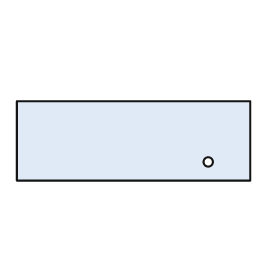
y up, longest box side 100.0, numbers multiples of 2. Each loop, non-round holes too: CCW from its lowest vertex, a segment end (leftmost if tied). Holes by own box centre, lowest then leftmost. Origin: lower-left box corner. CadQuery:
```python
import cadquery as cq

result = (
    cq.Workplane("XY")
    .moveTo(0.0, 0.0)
    .lineTo(100.0, 0.0)
    .lineTo(100.0, 34.0)
    .lineTo(0.0, 34.0)
    .close()
    .moveTo(82.0, 8.0)
    .circle(2.0)
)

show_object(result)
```